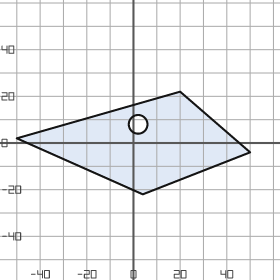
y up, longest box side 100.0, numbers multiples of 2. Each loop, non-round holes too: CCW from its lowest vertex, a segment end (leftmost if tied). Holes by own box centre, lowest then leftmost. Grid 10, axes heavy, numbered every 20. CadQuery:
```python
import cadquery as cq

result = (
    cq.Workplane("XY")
    .moveTo(4.0, -22.0)
    .lineTo(50.0, -4.0)
    .lineTo(20.0, 22.0)
    .lineTo(-50.0, 2.0)
    .close()
    .moveTo(2.0, 8.0)
    .circle(4.0)
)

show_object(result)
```